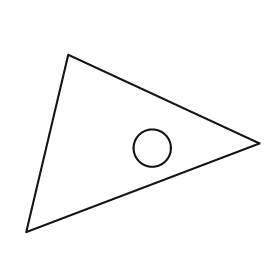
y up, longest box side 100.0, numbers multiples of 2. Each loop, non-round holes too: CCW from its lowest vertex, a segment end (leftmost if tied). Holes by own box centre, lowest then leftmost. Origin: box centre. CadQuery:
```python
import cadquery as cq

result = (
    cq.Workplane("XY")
    .moveTo(-50.0, -38.0)
    .lineTo(50.0, 0.0)
    .lineTo(-32.0, 38.0)
    .close()
    .moveTo(4.0, -2.0)
    .circle(8.0)
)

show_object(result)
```